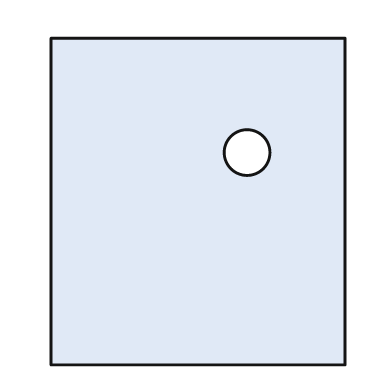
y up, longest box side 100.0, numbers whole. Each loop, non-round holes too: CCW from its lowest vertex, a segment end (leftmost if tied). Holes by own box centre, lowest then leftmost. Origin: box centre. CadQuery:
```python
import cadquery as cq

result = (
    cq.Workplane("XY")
    .moveTo(-45.0, -50.0)
    .lineTo(45.0, -50.0)
    .lineTo(45.0, 50.0)
    .lineTo(-45.0, 50.0)
    .close()
    .moveTo(15.0, 15.0)
    .circle(7.0)
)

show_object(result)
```